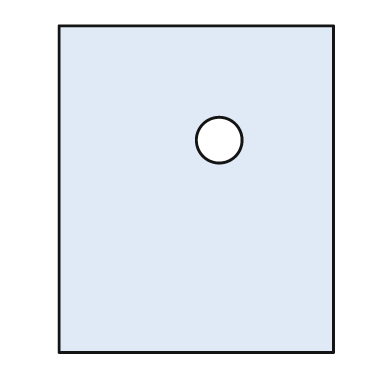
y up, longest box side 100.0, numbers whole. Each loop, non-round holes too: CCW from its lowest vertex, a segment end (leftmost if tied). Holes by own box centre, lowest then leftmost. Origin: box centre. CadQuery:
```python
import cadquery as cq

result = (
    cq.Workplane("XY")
    .moveTo(-42.0, -50.0)
    .lineTo(42.0, -50.0)
    .lineTo(42.0, 50.0)
    .lineTo(-42.0, 50.0)
    .close()
    .moveTo(7.0, 15.0)
    .circle(7.0)
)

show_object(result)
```